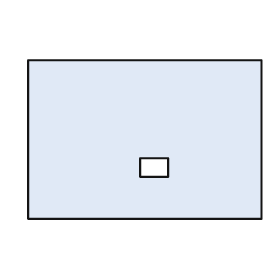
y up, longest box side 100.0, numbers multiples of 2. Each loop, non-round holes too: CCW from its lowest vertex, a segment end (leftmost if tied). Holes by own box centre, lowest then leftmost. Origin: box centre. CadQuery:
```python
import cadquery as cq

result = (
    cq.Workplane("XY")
    .moveTo(-50.0, -34.0)
    .lineTo(50.0, -34.0)
    .lineTo(50.0, 34.0)
    .lineTo(-50.0, 34.0)
    .close()
    .moveTo(-2.0, -16.0)
    .lineTo(10.0, -16.0)
    .lineTo(10.0, -8.0)
    .lineTo(-2.0, -8.0)
    .close()
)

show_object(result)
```